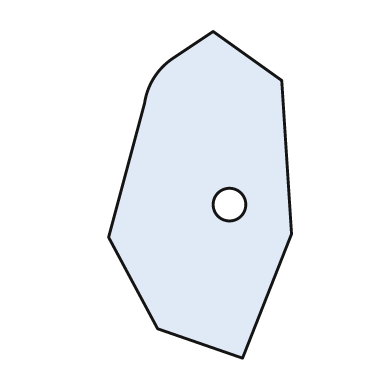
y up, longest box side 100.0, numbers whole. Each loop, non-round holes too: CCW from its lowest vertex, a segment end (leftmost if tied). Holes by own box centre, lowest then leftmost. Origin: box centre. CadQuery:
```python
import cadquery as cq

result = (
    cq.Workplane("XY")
    .moveTo(13.0, -50.0)
    .lineTo(28.0, -12.0)
    .lineTo(25.0, 35.0)
    .lineTo(4.0, 50.0)
    .lineTo(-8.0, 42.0)
    .threePointArc((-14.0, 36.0), (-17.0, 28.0))
    .lineTo(-28.0, -13.0)
    .lineTo(-13.0, -41.0)
    .close()
    .moveTo(9.0, -3.0)
    .circle(5.0)
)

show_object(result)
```